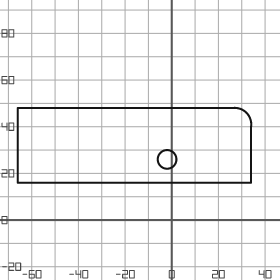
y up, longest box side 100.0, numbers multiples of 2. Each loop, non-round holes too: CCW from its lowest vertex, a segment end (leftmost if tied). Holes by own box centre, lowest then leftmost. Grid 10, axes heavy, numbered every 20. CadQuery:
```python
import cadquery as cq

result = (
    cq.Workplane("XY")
    .moveTo(-66.0, 16.0)
    .lineTo(34.0, 16.0)
    .lineTo(34.0, 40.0)
    .threePointArc((32.0, 46.0), (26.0, 48.0))
    .lineTo(-66.0, 48.0)
    .close()
    .moveTo(-2.0, 26.0)
    .circle(4.0)
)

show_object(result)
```